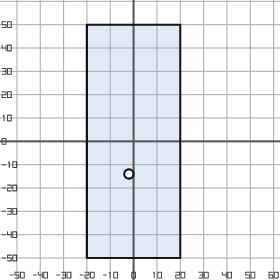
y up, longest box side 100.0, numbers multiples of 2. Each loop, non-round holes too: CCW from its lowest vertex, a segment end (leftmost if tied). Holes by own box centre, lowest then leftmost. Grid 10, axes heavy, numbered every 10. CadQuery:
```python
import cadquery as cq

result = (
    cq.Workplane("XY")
    .moveTo(-20.0, -50.0)
    .lineTo(20.0, -50.0)
    .lineTo(20.0, 50.0)
    .lineTo(-20.0, 50.0)
    .close()
    .moveTo(-2.0, -14.0)
    .circle(2.0)
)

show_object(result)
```